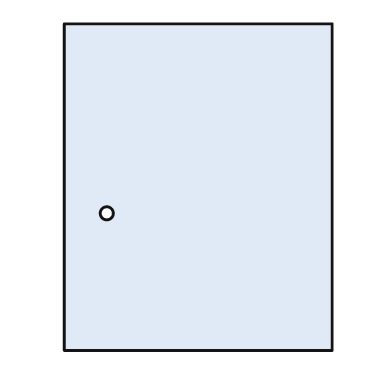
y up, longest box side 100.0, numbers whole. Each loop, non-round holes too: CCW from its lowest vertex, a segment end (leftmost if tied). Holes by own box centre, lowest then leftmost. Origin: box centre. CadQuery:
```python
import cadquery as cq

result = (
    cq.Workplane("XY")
    .moveTo(-41.0, -50.0)
    .lineTo(41.0, -50.0)
    .lineTo(41.0, 50.0)
    .lineTo(-41.0, 50.0)
    .close()
    .moveTo(-28.0, -8.0)
    .circle(2.0)
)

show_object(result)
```